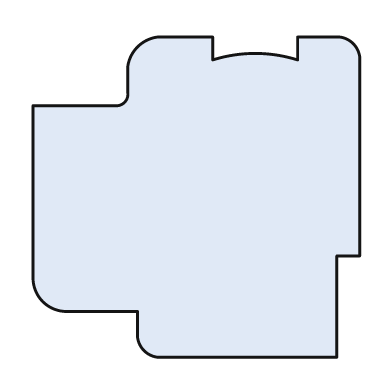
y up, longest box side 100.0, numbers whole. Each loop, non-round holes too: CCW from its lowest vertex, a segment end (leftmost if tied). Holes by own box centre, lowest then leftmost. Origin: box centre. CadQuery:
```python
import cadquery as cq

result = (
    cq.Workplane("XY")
    .moveTo(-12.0, -49.0)
    .lineTo(43.0, -49.0)
    .lineTo(43.0, -18.0)
    .lineTo(50.0, -18.0)
    .lineTo(50.0, 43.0)
    .threePointArc((48.0, 47.0), (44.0, 49.0))
    .lineTo(31.0, 49.0)
    .lineTo(31.0, 42.0)
    .threePointArc((18.0, 44.0), (5.0, 42.0))
    .lineTo(5.0, 49.0)
    .lineTo(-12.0, 49.0)
    .threePointArc((-18.0, 46.0), (-21.0, 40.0))
    .lineTo(-21.0, 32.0)
    .threePointArc((-22.0, 29.0), (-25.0, 28.0))
    .lineTo(-50.0, 28.0)
    .lineTo(-50.0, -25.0)
    .threePointArc((-47.0, -32.0), (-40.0, -35.0))
    .lineTo(-18.0, -35.0)
    .lineTo(-18.0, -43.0)
    .threePointArc((-16.0, -47.0), (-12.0, -49.0))
    .close()
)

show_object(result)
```